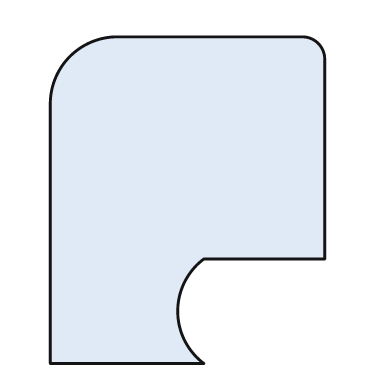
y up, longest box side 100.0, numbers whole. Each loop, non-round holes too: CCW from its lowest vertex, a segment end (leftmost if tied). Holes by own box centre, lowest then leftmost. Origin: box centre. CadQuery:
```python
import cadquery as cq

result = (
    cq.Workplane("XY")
    .moveTo(-42.0, -50.0)
    .lineTo(5.0, -50.0)
    .threePointArc((-3.0, -34.0), (5.0, -18.0))
    .lineTo(42.0, -18.0)
    .lineTo(42.0, 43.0)
    .threePointArc((40.0, 48.0), (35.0, 50.0))
    .lineTo(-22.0, 50.0)
    .threePointArc((-36.0, 44.0), (-42.0, 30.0))
    .close()
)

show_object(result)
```